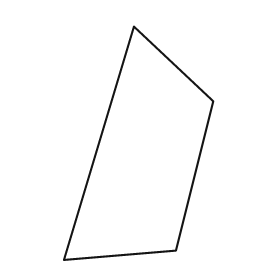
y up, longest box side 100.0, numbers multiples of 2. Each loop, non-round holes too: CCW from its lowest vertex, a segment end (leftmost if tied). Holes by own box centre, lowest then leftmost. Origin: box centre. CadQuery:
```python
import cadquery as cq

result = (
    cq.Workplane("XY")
    .moveTo(-32.0, -50.0)
    .lineTo(16.0, -46.0)
    .lineTo(32.0, 18.0)
    .lineTo(-2.0, 50.0)
    .close()
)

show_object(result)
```